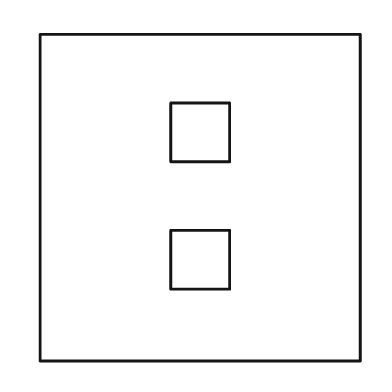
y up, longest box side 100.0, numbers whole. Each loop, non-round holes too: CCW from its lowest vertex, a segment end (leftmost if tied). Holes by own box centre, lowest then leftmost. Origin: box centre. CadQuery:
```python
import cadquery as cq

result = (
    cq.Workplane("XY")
    .moveTo(-49.0, -50.0)
    .lineTo(49.0, -50.0)
    .lineTo(49.0, 50.0)
    .lineTo(-49.0, 50.0)
    .close()
    .moveTo(-9.0, -28.0)
    .lineTo(9.0, -28.0)
    .lineTo(9.0, -10.0)
    .lineTo(-9.0, -10.0)
    .close()
    .moveTo(-9.0, 11.0)
    .lineTo(9.0, 11.0)
    .lineTo(9.0, 29.0)
    .lineTo(-9.0, 29.0)
    .close()
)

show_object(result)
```